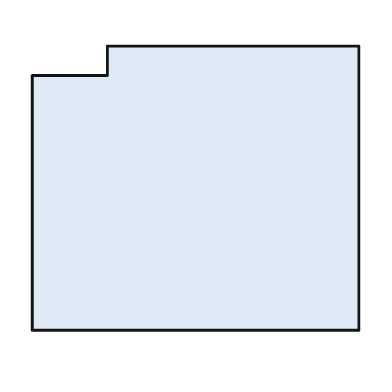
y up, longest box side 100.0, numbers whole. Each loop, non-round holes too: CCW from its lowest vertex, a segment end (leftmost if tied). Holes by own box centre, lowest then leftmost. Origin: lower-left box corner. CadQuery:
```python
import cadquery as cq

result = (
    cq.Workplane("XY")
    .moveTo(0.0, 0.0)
    .lineTo(100.0, 0.0)
    .lineTo(100.0, 87.0)
    .lineTo(23.0, 87.0)
    .lineTo(23.0, 78.0)
    .lineTo(0.0, 78.0)
    .close()
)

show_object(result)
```